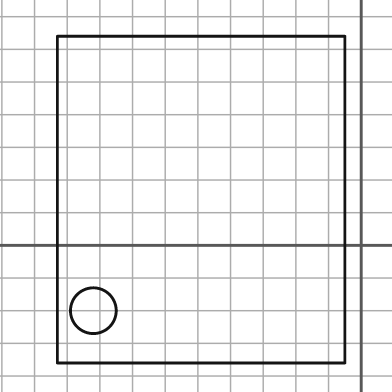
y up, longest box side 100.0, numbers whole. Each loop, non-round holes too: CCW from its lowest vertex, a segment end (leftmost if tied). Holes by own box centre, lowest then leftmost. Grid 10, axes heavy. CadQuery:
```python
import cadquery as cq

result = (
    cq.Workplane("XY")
    .moveTo(-93.0, -36.0)
    .lineTo(-5.0, -36.0)
    .lineTo(-5.0, 64.0)
    .lineTo(-93.0, 64.0)
    .close()
    .moveTo(-82.0, -20.0)
    .circle(7.0)
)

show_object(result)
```